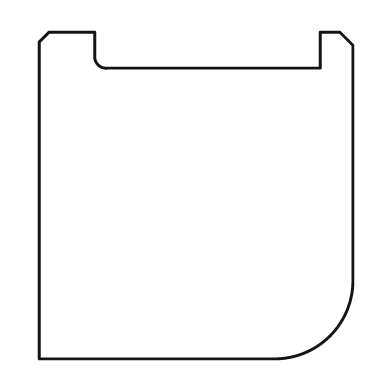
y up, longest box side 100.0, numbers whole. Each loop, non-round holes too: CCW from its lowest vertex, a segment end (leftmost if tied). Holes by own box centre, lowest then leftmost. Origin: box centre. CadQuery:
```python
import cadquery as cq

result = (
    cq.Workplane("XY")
    .moveTo(-48.0, -50.0)
    .lineTo(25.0, -50.0)
    .threePointArc((41.0, -43.0), (48.0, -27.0))
    .lineTo(48.0, 46.0)
    .lineTo(44.0, 50.0)
    .lineTo(38.0, 50.0)
    .lineTo(38.0, 39.0)
    .lineTo(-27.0, 39.0)
    .threePointArc((-30.0, 40.0), (-31.0, 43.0))
    .lineTo(-31.0, 50.0)
    .lineTo(-45.0, 50.0)
    .lineTo(-48.0, 47.0)
    .close()
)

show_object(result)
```